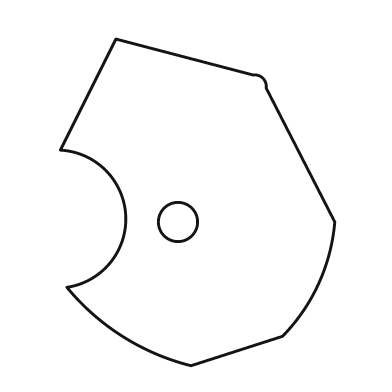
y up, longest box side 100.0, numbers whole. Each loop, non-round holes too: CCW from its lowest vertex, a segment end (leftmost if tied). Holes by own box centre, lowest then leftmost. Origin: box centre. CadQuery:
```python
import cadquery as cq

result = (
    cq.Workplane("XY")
    .moveTo(-2.0, -50.0)
    .lineTo(26.0, -41.0)
    .threePointArc((37.0, -25.0), (42.0, -6.0))
    .lineTo(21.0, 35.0)
    .threePointArc((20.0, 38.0), (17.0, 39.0))
    .lineTo(-25.0, 50.0)
    .lineTo(-42.0, 16.0)
    .threePointArc((-22.0, -4.0), (-40.0, -26.0))
    .threePointArc((-23.0, -41.0), (-2.0, -50.0))
    .close()
    .moveTo(-6.0, -6.0)
    .circle(6.0)
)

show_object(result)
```